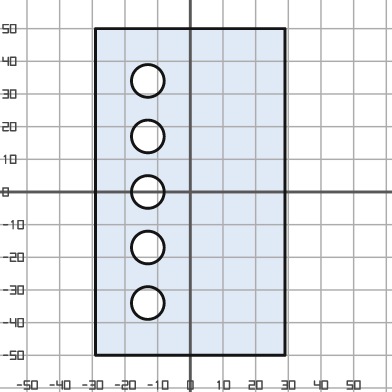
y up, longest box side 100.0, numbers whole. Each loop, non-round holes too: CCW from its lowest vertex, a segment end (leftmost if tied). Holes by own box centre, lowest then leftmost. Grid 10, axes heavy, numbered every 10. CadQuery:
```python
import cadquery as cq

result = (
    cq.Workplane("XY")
    .moveTo(-29.0, -50.0)
    .lineTo(29.0, -50.0)
    .lineTo(29.0, 50.0)
    .lineTo(-29.0, 50.0)
    .close()
    .moveTo(-13.0, -34.0)
    .circle(5.0)
    .moveTo(-13.0, -17.0)
    .circle(5.0)
    .moveTo(-13.0, 0.0)
    .circle(5.0)
    .moveTo(-13.0, 17.0)
    .circle(5.0)
    .moveTo(-13.0, 34.0)
    .circle(5.0)
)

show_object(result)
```